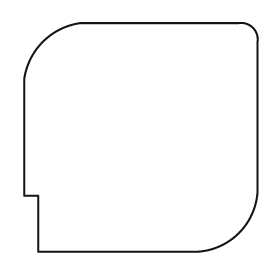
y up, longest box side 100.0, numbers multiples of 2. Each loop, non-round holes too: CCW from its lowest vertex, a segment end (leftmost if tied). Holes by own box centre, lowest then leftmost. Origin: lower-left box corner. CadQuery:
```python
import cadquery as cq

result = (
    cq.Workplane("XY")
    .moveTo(6.0, 0.0)
    .lineTo(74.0, 0.0)
    .threePointArc((92.0, 8.0), (100.0, 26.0))
    .lineTo(100.0, 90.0)
    .threePointArc((98.0, 96.0), (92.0, 98.0))
    .lineTo(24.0, 98.0)
    .threePointArc((8.0, 90.0), (0.0, 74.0))
    .lineTo(0.0, 24.0)
    .lineTo(6.0, 24.0)
    .close()
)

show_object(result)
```